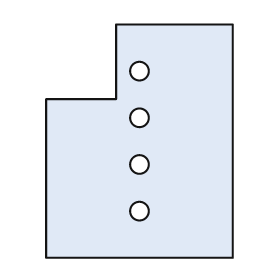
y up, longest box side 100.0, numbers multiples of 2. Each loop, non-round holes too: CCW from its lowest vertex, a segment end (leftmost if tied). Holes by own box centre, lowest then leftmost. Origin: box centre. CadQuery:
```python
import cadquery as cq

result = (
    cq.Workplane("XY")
    .moveTo(-40.0, -50.0)
    .lineTo(40.0, -50.0)
    .lineTo(40.0, 50.0)
    .lineTo(-10.0, 50.0)
    .lineTo(-10.0, 18.0)
    .lineTo(-40.0, 18.0)
    .close()
    .moveTo(0.0, -30.0)
    .circle(4.0)
    .moveTo(0.0, -10.0)
    .circle(4.0)
    .moveTo(0.0, 10.0)
    .circle(4.0)
    .moveTo(0.0, 30.0)
    .circle(4.0)
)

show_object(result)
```